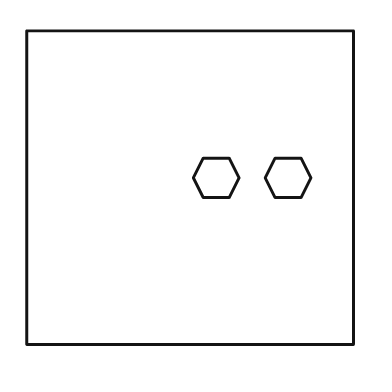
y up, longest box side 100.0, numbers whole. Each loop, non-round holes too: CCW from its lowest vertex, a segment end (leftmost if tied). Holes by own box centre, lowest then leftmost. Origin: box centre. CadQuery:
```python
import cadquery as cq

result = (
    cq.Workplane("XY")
    .moveTo(-50.0, -48.0)
    .lineTo(50.0, -48.0)
    .lineTo(50.0, 48.0)
    .lineTo(-50.0, 48.0)
    .close()
    .moveTo(4.0, -3.0)
    .lineTo(12.0, -3.0)
    .lineTo(15.0, 3.0)
    .lineTo(12.0, 9.0)
    .lineTo(4.0, 9.0)
    .lineTo(1.0, 3.0)
    .close()
    .moveTo(26.0, -3.0)
    .lineTo(34.0, -3.0)
    .lineTo(37.0, 3.0)
    .lineTo(34.0, 9.0)
    .lineTo(26.0, 9.0)
    .lineTo(23.0, 3.0)
    .close()
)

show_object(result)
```